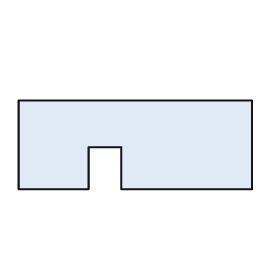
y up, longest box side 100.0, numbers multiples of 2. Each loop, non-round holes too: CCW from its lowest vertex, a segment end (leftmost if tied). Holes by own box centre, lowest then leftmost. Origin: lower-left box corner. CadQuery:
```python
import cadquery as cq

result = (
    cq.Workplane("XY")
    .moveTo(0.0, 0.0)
    .lineTo(30.0, 0.0)
    .lineTo(30.0, 18.0)
    .lineTo(44.0, 18.0)
    .lineTo(44.0, 0.0)
    .lineTo(100.0, 0.0)
    .lineTo(100.0, 38.0)
    .lineTo(0.0, 38.0)
    .close()
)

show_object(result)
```